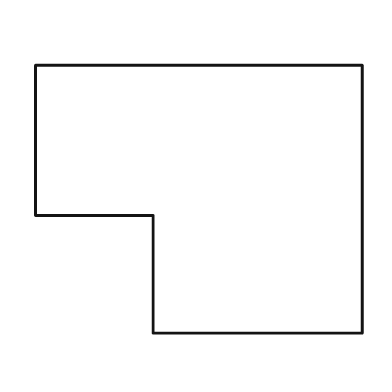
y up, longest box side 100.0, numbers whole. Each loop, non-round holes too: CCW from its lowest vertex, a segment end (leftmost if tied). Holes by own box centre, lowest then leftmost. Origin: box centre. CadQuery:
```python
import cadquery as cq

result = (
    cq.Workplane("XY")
    .moveTo(-14.0, -41.0)
    .lineTo(50.0, -41.0)
    .lineTo(50.0, 41.0)
    .lineTo(-50.0, 41.0)
    .lineTo(-50.0, -5.0)
    .lineTo(-14.0, -5.0)
    .close()
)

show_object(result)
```